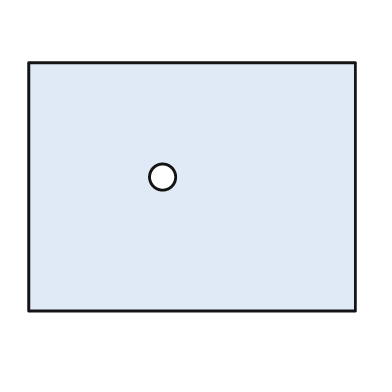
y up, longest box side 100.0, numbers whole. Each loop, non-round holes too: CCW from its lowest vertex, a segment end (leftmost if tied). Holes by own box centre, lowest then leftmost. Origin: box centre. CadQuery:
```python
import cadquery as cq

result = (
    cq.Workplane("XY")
    .moveTo(-50.0, -38.0)
    .lineTo(50.0, -38.0)
    .lineTo(50.0, 38.0)
    .lineTo(-50.0, 38.0)
    .close()
    .moveTo(-9.0, 3.0)
    .circle(4.0)
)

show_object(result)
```